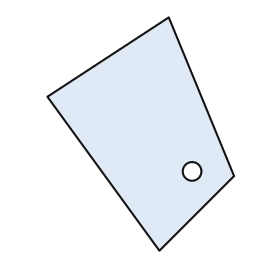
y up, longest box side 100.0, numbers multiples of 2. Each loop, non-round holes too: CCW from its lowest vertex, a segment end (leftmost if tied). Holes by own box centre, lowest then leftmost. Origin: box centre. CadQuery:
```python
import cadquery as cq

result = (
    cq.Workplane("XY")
    .moveTo(8.0, -50.0)
    .lineTo(40.0, -18.0)
    .lineTo(12.0, 50.0)
    .lineTo(-40.0, 16.0)
    .close()
    .moveTo(22.0, -16.0)
    .circle(4.0)
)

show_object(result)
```